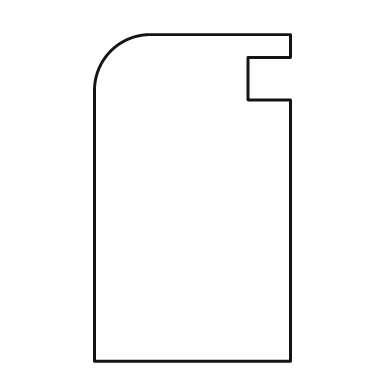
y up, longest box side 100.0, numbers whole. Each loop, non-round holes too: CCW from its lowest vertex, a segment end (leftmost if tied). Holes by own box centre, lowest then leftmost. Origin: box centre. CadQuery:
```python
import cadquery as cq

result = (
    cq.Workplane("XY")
    .moveTo(-30.0, -50.0)
    .lineTo(30.0, -50.0)
    .lineTo(30.0, 30.0)
    .lineTo(17.0, 30.0)
    .lineTo(17.0, 43.0)
    .lineTo(30.0, 43.0)
    .lineTo(30.0, 50.0)
    .lineTo(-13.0, 50.0)
    .threePointArc((-25.0, 45.0), (-30.0, 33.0))
    .close()
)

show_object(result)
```